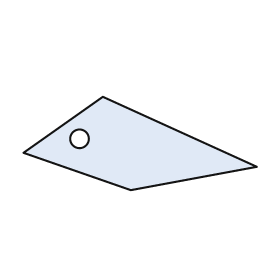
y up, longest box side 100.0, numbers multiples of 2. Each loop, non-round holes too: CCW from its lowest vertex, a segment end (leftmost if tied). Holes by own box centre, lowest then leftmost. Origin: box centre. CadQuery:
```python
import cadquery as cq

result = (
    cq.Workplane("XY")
    .moveTo(-4.0, -20.0)
    .lineTo(50.0, -10.0)
    .lineTo(-16.0, 20.0)
    .lineTo(-50.0, -4.0)
    .close()
    .moveTo(-26.0, 2.0)
    .circle(4.0)
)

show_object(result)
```